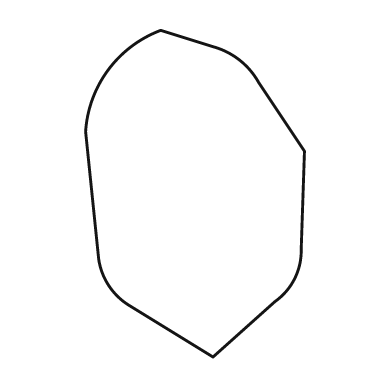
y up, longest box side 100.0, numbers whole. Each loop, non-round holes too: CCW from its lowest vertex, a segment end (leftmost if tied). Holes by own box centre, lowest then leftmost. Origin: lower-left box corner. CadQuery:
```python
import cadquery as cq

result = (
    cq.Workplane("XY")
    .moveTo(39.0, 0.0)
    .lineTo(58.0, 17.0)
    .threePointArc((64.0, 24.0), (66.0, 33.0))
    .lineTo(67.0, 63.0)
    .lineTo(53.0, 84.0)
    .threePointArc((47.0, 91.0), (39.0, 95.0))
    .lineTo(23.0, 100.0)
    .threePointArc((7.0, 88.0), (0.0, 69.0))
    .lineTo(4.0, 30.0)
    .threePointArc((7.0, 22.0), (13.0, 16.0))
    .close()
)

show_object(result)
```